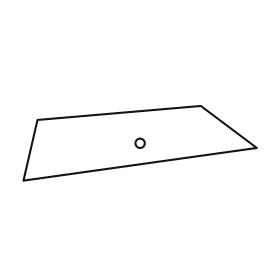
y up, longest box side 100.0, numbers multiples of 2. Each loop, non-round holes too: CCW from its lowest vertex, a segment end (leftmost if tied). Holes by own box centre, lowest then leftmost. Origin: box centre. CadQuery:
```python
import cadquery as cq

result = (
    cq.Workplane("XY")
    .moveTo(-50.0, -16.0)
    .lineTo(50.0, -2.0)
    .lineTo(26.0, 16.0)
    .lineTo(-44.0, 10.0)
    .close()
    .moveTo(0.0, 0.0)
    .circle(2.0)
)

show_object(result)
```